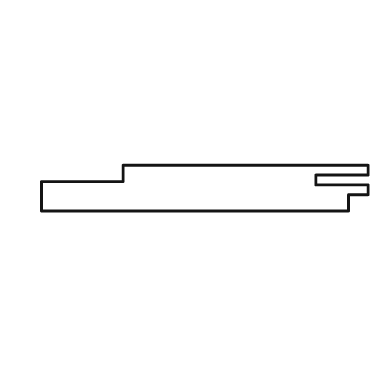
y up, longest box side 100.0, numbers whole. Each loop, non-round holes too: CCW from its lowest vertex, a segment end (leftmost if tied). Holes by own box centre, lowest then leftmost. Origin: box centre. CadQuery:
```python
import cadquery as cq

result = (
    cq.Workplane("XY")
    .moveTo(-50.0, -7.0)
    .lineTo(44.0, -7.0)
    .lineTo(44.0, -2.0)
    .lineTo(50.0, -2.0)
    .lineTo(50.0, 1.0)
    .lineTo(34.0, 1.0)
    .lineTo(34.0, 4.0)
    .lineTo(50.0, 4.0)
    .lineTo(50.0, 7.0)
    .lineTo(-25.0, 7.0)
    .lineTo(-25.0, 2.0)
    .lineTo(-50.0, 2.0)
    .close()
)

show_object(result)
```